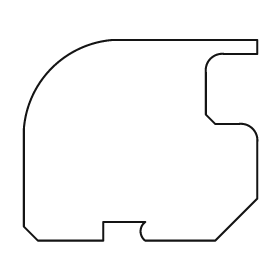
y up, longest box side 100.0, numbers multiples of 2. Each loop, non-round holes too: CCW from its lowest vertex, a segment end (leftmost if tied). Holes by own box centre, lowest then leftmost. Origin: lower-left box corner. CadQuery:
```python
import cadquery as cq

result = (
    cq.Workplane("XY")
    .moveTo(6.0, 0.0)
    .lineTo(34.0, 0.0)
    .lineTo(34.0, 8.0)
    .lineTo(52.0, 8.0)
    .threePointArc((50.0, 4.0), (52.0, 0.0))
    .lineTo(82.0, 0.0)
    .lineTo(100.0, 18.0)
    .lineTo(100.0, 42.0)
    .threePointArc((98.0, 48.0), (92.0, 50.0))
    .lineTo(82.0, 50.0)
    .lineTo(78.0, 54.0)
    .lineTo(78.0, 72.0)
    .threePointArc((80.0, 78.0), (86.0, 80.0))
    .lineTo(100.0, 80.0)
    .lineTo(100.0, 86.0)
    .lineTo(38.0, 86.0)
    .threePointArc((12.0, 74.0), (0.0, 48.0))
    .lineTo(0.0, 6.0)
    .close()
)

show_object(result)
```